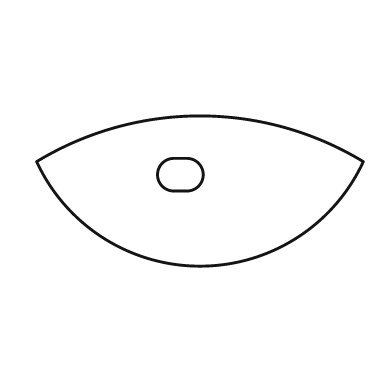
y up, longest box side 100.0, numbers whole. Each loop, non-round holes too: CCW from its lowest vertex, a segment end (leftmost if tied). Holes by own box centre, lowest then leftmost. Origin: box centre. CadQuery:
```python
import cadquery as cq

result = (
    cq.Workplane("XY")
    .moveTo(-50.0, 9.0)
    .threePointArc((0.0, -23.0), (50.0, 9.0))
    .threePointArc((0.0, 23.0), (-50.0, 9.0))
    .close()
    .moveTo(-8.0, 0.0)
    .lineTo(-4.0, 0.0)
    .threePointArc((1.0, 5.0), (-4.0, 10.0))
    .lineTo(-8.0, 10.0)
    .threePointArc((-13.0, 5.0), (-8.0, 0.0))
    .close()
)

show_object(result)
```